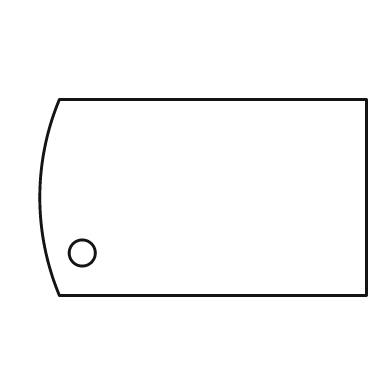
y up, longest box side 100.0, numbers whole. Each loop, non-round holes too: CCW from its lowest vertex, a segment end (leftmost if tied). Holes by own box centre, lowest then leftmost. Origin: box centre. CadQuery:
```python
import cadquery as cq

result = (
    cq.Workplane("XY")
    .moveTo(-44.0, -30.0)
    .lineTo(50.0, -30.0)
    .lineTo(50.0, 30.0)
    .lineTo(-44.0, 30.0)
    .threePointArc((-50.0, 0.0), (-44.0, -30.0))
    .close()
    .moveTo(-37.0, -17.0)
    .circle(4.0)
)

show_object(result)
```